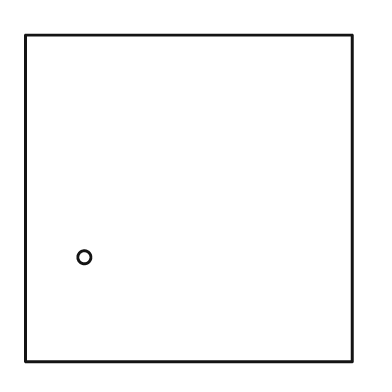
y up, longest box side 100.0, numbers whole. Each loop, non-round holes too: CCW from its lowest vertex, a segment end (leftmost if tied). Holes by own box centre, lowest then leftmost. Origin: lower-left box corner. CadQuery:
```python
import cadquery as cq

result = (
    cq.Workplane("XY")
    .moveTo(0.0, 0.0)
    .lineTo(100.0, 0.0)
    .lineTo(100.0, 100.0)
    .lineTo(0.0, 100.0)
    .close()
    .moveTo(18.0, 32.0)
    .circle(2.0)
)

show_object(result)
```